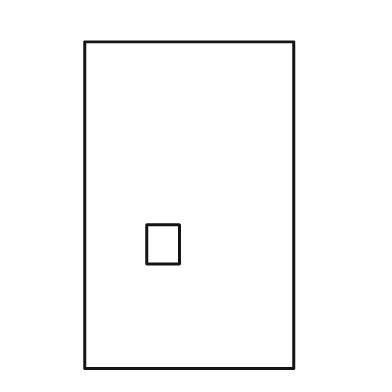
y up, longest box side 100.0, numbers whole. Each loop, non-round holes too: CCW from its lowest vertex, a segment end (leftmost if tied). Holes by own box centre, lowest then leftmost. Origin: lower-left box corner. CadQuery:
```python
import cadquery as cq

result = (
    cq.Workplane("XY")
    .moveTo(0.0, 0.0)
    .lineTo(64.0, 0.0)
    .lineTo(64.0, 100.0)
    .lineTo(0.0, 100.0)
    .close()
    .moveTo(19.0, 32.0)
    .lineTo(29.0, 32.0)
    .lineTo(29.0, 44.0)
    .lineTo(19.0, 44.0)
    .close()
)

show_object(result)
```